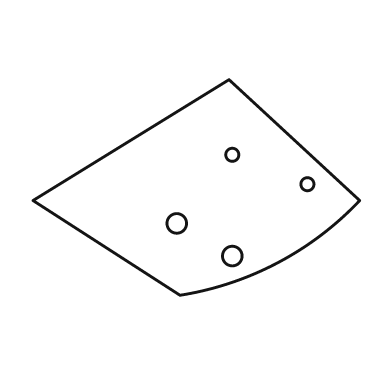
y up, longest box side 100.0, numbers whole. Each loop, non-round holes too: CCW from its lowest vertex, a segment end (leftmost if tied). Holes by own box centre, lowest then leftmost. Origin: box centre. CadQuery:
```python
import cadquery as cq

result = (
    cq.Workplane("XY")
    .moveTo(-5.0, -33.0)
    .threePointArc((25.0, -23.0), (50.0, -4.0))
    .lineTo(10.0, 33.0)
    .lineTo(-50.0, -4.0)
    .close()
    .moveTo(11.0, -21.0)
    .circle(3.0)
    .moveTo(-6.0, -11.0)
    .circle(3.0)
    .moveTo(34.0, 1.0)
    .circle(2.0)
    .moveTo(11.0, 10.0)
    .circle(2.0)
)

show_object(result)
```